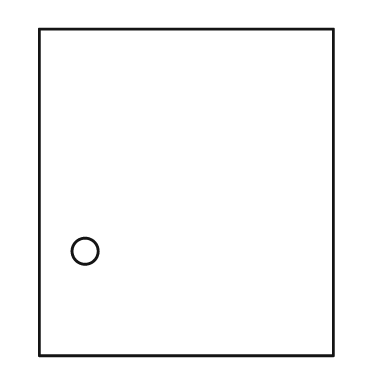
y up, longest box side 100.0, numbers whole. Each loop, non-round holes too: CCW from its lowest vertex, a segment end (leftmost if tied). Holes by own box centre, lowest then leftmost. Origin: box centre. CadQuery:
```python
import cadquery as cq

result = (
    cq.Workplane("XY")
    .moveTo(-45.0, -50.0)
    .lineTo(45.0, -50.0)
    .lineTo(45.0, 50.0)
    .lineTo(-45.0, 50.0)
    .close()
    .moveTo(-31.0, -18.0)
    .circle(4.0)
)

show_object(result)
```